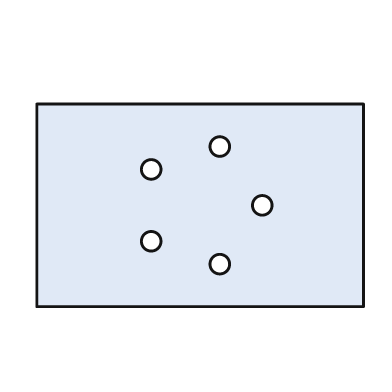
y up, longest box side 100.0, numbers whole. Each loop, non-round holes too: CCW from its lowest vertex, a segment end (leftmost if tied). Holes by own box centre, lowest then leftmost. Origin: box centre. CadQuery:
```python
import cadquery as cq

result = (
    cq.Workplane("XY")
    .moveTo(-50.0, -31.0)
    .lineTo(50.0, -31.0)
    .lineTo(50.0, 31.0)
    .lineTo(-50.0, 31.0)
    .close()
    .moveTo(6.0, -18.0)
    .circle(3.0)
    .moveTo(-15.0, -11.0)
    .circle(3.0)
    .moveTo(19.0, 0.0)
    .circle(3.0)
    .moveTo(-15.0, 11.0)
    .circle(3.0)
    .moveTo(6.0, 18.0)
    .circle(3.0)
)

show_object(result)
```